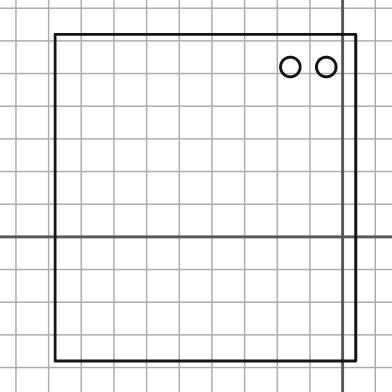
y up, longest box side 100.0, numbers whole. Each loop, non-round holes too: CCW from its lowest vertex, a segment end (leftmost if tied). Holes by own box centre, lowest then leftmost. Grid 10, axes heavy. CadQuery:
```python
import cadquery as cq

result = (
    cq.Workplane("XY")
    .moveTo(-88.0, -38.0)
    .lineTo(4.0, -38.0)
    .lineTo(4.0, 62.0)
    .lineTo(-88.0, 62.0)
    .close()
    .moveTo(-16.0, 52.0)
    .circle(3.0)
    .moveTo(-5.0, 52.0)
    .circle(3.0)
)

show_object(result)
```